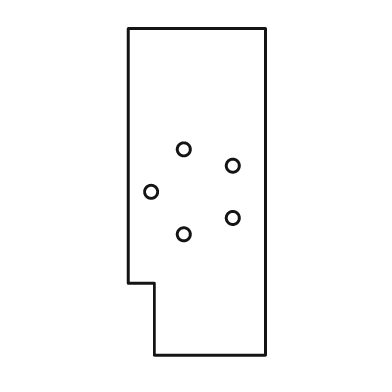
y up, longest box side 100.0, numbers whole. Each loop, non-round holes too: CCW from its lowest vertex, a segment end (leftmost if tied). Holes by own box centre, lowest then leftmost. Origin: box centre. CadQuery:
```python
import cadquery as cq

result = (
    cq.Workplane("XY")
    .moveTo(-13.0, -50.0)
    .lineTo(21.0, -50.0)
    .lineTo(21.0, 50.0)
    .lineTo(-21.0, 50.0)
    .lineTo(-21.0, -28.0)
    .lineTo(-13.0, -28.0)
    .close()
    .moveTo(-4.0, -13.0)
    .circle(2.0)
    .moveTo(11.0, -8.0)
    .circle(2.0)
    .moveTo(-14.0, 0.0)
    .circle(2.0)
    .moveTo(11.0, 8.0)
    .circle(2.0)
    .moveTo(-4.0, 13.0)
    .circle(2.0)
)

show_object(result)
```